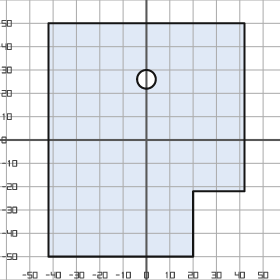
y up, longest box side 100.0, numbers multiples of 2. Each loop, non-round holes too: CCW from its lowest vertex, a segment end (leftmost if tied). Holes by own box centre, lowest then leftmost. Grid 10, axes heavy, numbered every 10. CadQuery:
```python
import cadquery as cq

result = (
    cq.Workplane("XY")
    .moveTo(-42.0, -50.0)
    .lineTo(20.0, -50.0)
    .lineTo(20.0, -22.0)
    .lineTo(42.0, -22.0)
    .lineTo(42.0, 50.0)
    .lineTo(-42.0, 50.0)
    .close()
    .moveTo(0.0, 26.0)
    .circle(4.0)
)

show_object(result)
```